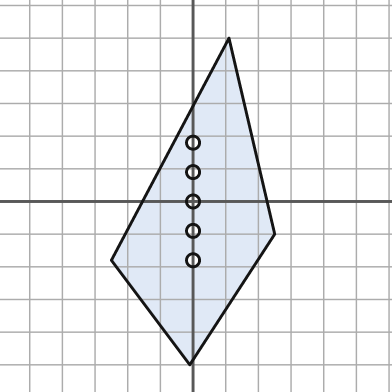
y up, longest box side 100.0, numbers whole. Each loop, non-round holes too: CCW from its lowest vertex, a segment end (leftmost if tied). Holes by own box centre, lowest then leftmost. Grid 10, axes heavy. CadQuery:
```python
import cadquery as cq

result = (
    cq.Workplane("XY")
    .moveTo(-1.0, -50.0)
    .lineTo(25.0, -10.0)
    .lineTo(11.0, 50.0)
    .lineTo(-25.0, -18.0)
    .close()
    .moveTo(0.0, -18.0)
    .circle(2.0)
    .moveTo(0.0, -9.0)
    .circle(2.0)
    .moveTo(0.0, 0.0)
    .circle(2.0)
    .moveTo(0.0, 9.0)
    .circle(2.0)
    .moveTo(0.0, 18.0)
    .circle(2.0)
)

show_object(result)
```